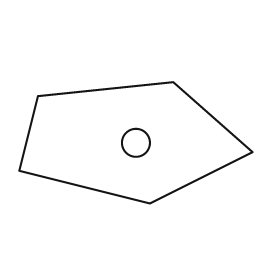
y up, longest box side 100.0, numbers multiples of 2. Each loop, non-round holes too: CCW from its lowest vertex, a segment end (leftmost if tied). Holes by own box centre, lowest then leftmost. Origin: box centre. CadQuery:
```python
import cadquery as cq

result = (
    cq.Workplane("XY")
    .moveTo(6.0, -26.0)
    .lineTo(50.0, -4.0)
    .lineTo(16.0, 26.0)
    .lineTo(-42.0, 20.0)
    .lineTo(-50.0, -12.0)
    .close()
    .moveTo(0.0, 0.0)
    .circle(6.0)
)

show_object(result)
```